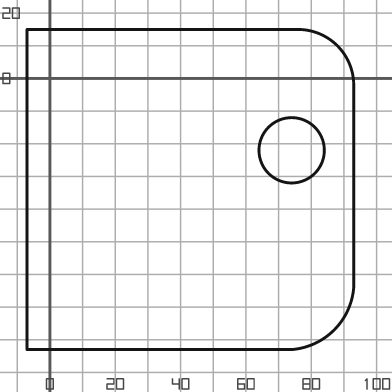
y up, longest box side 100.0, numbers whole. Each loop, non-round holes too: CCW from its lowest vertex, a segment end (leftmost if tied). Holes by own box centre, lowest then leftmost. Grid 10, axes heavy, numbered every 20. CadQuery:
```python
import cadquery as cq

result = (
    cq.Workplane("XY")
    .moveTo(-7.0, -83.0)
    .lineTo(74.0, -83.0)
    .threePointArc((87.0, -77.0), (93.0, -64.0))
    .lineTo(93.0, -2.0)
    .threePointArc((88.0, 10.0), (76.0, 15.0))
    .lineTo(-7.0, 15.0)
    .close()
    .moveTo(74.0, -22.0)
    .circle(10.0)
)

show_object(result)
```